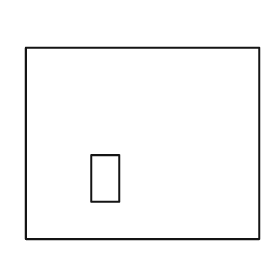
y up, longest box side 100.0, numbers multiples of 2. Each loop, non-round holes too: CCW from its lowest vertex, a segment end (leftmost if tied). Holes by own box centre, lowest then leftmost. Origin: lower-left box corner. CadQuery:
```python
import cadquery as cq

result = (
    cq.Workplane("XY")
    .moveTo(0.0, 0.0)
    .lineTo(100.0, 0.0)
    .lineTo(100.0, 82.0)
    .lineTo(0.0, 82.0)
    .close()
    .moveTo(28.0, 16.0)
    .lineTo(40.0, 16.0)
    .lineTo(40.0, 36.0)
    .lineTo(28.0, 36.0)
    .close()
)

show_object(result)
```